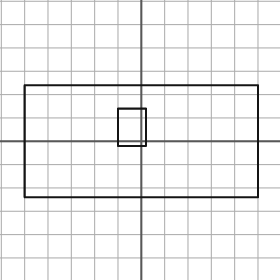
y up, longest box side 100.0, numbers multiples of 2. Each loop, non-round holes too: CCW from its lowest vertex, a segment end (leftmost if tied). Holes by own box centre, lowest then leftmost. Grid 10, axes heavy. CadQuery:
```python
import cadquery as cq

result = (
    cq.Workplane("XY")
    .moveTo(-50.0, -24.0)
    .lineTo(50.0, -24.0)
    .lineTo(50.0, 24.0)
    .lineTo(-50.0, 24.0)
    .close()
    .moveTo(-10.0, -2.0)
    .lineTo(2.0, -2.0)
    .lineTo(2.0, 14.0)
    .lineTo(-10.0, 14.0)
    .close()
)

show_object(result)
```